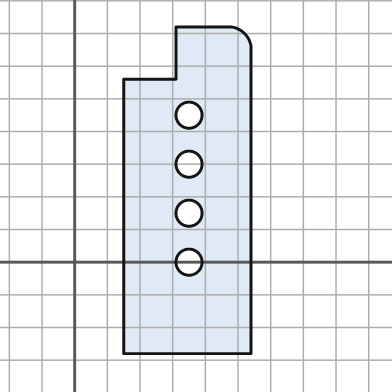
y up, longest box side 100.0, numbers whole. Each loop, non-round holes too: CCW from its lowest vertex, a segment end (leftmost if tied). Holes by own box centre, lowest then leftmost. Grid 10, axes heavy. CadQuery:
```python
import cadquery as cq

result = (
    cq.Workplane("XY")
    .moveTo(15.0, -28.0)
    .lineTo(54.0, -28.0)
    .lineTo(54.0, 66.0)
    .threePointArc((52.0, 70.0), (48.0, 72.0))
    .lineTo(31.0, 72.0)
    .lineTo(31.0, 56.0)
    .lineTo(15.0, 56.0)
    .close()
    .moveTo(35.0, 0.0)
    .circle(4.0)
    .moveTo(35.0, 15.0)
    .circle(4.0)
    .moveTo(35.0, 30.0)
    .circle(4.0)
    .moveTo(35.0, 45.0)
    .circle(4.0)
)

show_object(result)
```